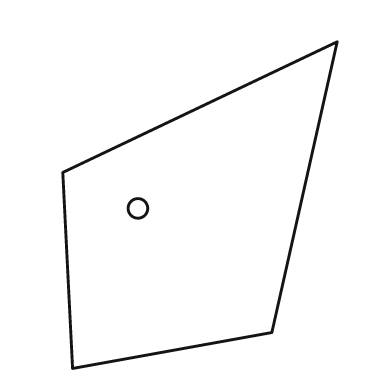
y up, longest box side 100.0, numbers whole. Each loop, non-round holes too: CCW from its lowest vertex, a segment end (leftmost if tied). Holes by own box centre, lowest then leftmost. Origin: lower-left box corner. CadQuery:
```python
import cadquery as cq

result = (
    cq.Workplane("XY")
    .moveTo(3.0, 0.0)
    .lineTo(64.0, 11.0)
    .lineTo(84.0, 100.0)
    .lineTo(0.0, 60.0)
    .close()
    .moveTo(23.0, 49.0)
    .circle(3.0)
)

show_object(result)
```